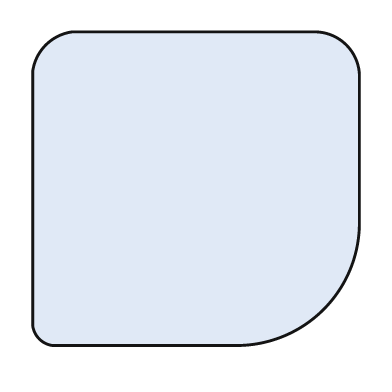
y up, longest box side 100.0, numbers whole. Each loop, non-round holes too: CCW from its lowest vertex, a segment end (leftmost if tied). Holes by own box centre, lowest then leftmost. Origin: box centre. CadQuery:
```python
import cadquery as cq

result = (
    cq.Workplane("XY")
    .moveTo(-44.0, -48.0)
    .lineTo(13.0, -48.0)
    .threePointArc((39.0, -37.0), (50.0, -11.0))
    .lineTo(50.0, 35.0)
    .threePointArc((46.0, 44.0), (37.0, 48.0))
    .lineTo(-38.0, 48.0)
    .threePointArc((-46.0, 44.0), (-50.0, 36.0))
    .lineTo(-50.0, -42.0)
    .threePointArc((-48.0, -46.0), (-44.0, -48.0))
    .close()
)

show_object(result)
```